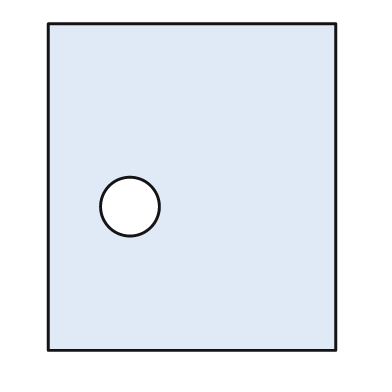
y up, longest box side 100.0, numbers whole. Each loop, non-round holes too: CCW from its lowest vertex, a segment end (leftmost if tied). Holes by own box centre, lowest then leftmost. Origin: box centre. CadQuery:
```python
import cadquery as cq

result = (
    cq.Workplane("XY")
    .moveTo(-44.0, -50.0)
    .lineTo(44.0, -50.0)
    .lineTo(44.0, 50.0)
    .lineTo(-44.0, 50.0)
    .close()
    .moveTo(-19.0, -6.0)
    .circle(9.0)
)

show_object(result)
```